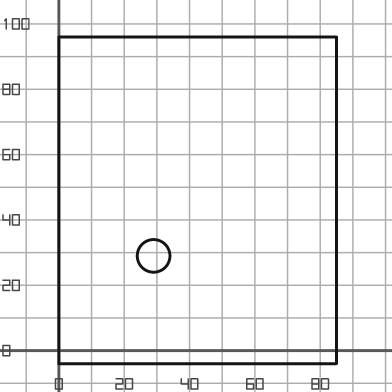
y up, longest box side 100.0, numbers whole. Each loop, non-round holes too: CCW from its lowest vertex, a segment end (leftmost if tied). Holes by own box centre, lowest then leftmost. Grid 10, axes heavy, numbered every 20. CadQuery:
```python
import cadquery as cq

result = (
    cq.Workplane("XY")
    .moveTo(0.0, -4.0)
    .lineTo(85.0, -4.0)
    .lineTo(85.0, 96.0)
    .lineTo(0.0, 96.0)
    .close()
    .moveTo(29.0, 29.0)
    .circle(5.0)
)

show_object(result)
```